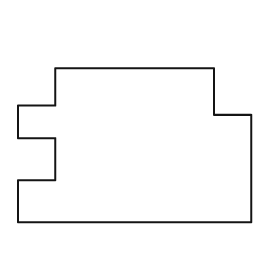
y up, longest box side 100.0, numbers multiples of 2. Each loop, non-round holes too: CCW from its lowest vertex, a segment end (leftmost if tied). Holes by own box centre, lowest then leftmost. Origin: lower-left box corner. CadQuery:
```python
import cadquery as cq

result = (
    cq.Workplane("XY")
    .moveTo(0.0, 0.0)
    .lineTo(100.0, 0.0)
    .lineTo(100.0, 46.0)
    .lineTo(84.0, 46.0)
    .lineTo(84.0, 66.0)
    .lineTo(16.0, 66.0)
    .lineTo(16.0, 50.0)
    .lineTo(0.0, 50.0)
    .lineTo(0.0, 36.0)
    .lineTo(16.0, 36.0)
    .lineTo(16.0, 18.0)
    .lineTo(0.0, 18.0)
    .close()
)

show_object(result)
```